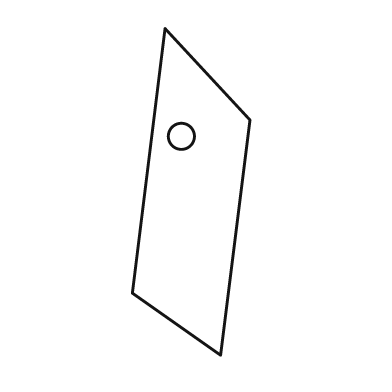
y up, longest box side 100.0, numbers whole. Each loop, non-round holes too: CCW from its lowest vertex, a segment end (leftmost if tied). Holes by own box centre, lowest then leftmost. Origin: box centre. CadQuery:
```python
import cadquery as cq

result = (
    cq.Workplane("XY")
    .moveTo(9.0, -50.0)
    .lineTo(18.0, 22.0)
    .lineTo(-8.0, 50.0)
    .lineTo(-18.0, -31.0)
    .close()
    .moveTo(-3.0, 17.0)
    .circle(4.0)
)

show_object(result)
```